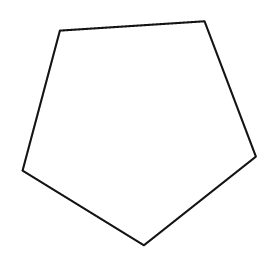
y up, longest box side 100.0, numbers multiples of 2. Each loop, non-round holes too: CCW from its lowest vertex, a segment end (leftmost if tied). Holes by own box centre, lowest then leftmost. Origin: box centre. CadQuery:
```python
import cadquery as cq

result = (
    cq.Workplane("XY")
    .moveTo(2.0, -48.0)
    .lineTo(50.0, -10.0)
    .lineTo(28.0, 48.0)
    .lineTo(-34.0, 44.0)
    .lineTo(-50.0, -16.0)
    .close()
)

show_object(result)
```